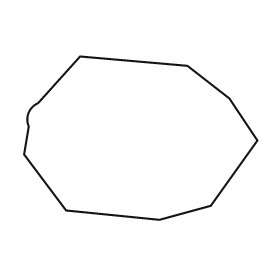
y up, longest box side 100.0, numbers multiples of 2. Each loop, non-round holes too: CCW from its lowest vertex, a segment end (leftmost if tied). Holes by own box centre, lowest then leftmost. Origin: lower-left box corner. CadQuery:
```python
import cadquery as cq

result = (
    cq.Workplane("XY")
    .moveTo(58.0, 0.0)
    .lineTo(80.0, 6.0)
    .lineTo(100.0, 34.0)
    .lineTo(88.0, 52.0)
    .lineTo(70.0, 66.0)
    .lineTo(24.0, 70.0)
    .lineTo(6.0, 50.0)
    .threePointArc((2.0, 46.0), (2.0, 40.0))
    .lineTo(0.0, 28.0)
    .lineTo(18.0, 4.0)
    .close()
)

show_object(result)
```